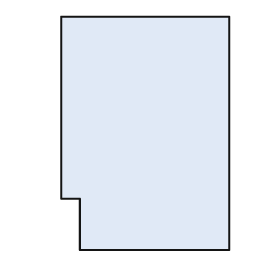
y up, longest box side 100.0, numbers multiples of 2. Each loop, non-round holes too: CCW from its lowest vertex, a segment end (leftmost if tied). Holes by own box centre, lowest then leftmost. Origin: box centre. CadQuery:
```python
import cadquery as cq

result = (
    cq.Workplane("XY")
    .moveTo(-28.0, -50.0)
    .lineTo(36.0, -50.0)
    .lineTo(36.0, 50.0)
    .lineTo(-36.0, 50.0)
    .lineTo(-36.0, -28.0)
    .lineTo(-28.0, -28.0)
    .close()
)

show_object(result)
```